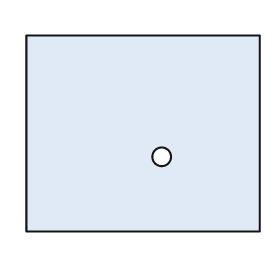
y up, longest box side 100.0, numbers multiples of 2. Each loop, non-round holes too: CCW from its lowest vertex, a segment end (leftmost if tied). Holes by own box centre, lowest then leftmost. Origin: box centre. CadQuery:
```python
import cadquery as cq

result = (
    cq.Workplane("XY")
    .moveTo(-50.0, -42.0)
    .lineTo(50.0, -42.0)
    .lineTo(50.0, 42.0)
    .lineTo(-50.0, 42.0)
    .close()
    .moveTo(8.0, -10.0)
    .circle(4.0)
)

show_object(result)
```